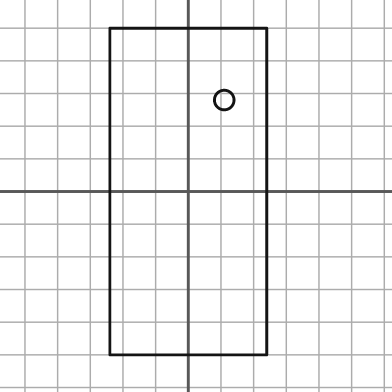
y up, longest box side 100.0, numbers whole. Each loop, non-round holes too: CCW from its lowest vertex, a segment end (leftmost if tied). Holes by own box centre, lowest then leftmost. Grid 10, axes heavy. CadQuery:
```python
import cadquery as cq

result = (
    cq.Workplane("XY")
    .moveTo(-24.0, -50.0)
    .lineTo(24.0, -50.0)
    .lineTo(24.0, 50.0)
    .lineTo(-24.0, 50.0)
    .close()
    .moveTo(11.0, 28.0)
    .circle(3.0)
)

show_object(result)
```